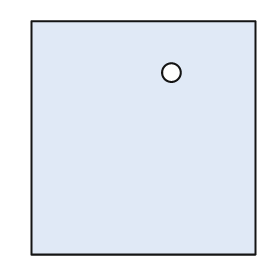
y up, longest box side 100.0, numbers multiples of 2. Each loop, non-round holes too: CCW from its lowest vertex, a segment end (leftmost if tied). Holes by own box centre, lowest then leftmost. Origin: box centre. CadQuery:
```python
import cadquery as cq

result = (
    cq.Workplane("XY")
    .moveTo(-48.0, -50.0)
    .lineTo(48.0, -50.0)
    .lineTo(48.0, 50.0)
    .lineTo(-48.0, 50.0)
    .close()
    .moveTo(12.0, 28.0)
    .circle(4.0)
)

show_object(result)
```